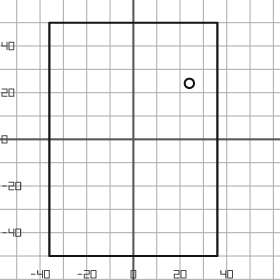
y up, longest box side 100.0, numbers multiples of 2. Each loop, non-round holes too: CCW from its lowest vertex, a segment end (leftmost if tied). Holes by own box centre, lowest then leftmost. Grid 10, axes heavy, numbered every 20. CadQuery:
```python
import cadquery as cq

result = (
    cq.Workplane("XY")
    .moveTo(-36.0, -50.0)
    .lineTo(36.0, -50.0)
    .lineTo(36.0, 50.0)
    .lineTo(-36.0, 50.0)
    .close()
    .moveTo(24.0, 24.0)
    .circle(2.0)
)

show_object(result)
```